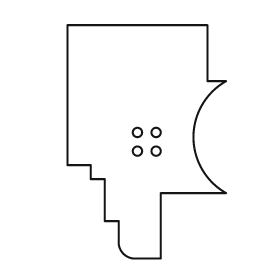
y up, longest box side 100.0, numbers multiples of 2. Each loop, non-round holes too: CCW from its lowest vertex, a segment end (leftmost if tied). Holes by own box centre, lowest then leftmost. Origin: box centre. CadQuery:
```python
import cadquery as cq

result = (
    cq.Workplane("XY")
    .moveTo(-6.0, -50.0)
    .lineTo(6.0, -50.0)
    .lineTo(6.0, -22.0)
    .lineTo(34.0, -22.0)
    .threePointArc((20.0, 2.0), (34.0, 26.0))
    .lineTo(26.0, 26.0)
    .lineTo(26.0, 50.0)
    .lineTo(-34.0, 50.0)
    .lineTo(-34.0, -10.0)
    .lineTo(-24.0, -10.0)
    .lineTo(-24.0, -16.0)
    .lineTo(-18.0, -16.0)
    .lineTo(-18.0, -34.0)
    .lineTo(-12.0, -34.0)
    .lineTo(-12.0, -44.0)
    .threePointArc((-10.0, -48.0), (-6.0, -50.0))
    .close()
    .moveTo(-4.0, -4.0)
    .circle(2.0)
    .moveTo(4.0, -4.0)
    .circle(2.0)
    .moveTo(-4.0, 4.0)
    .circle(2.0)
    .moveTo(4.0, 4.0)
    .circle(2.0)
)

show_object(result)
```